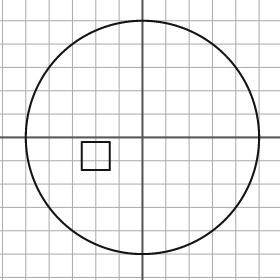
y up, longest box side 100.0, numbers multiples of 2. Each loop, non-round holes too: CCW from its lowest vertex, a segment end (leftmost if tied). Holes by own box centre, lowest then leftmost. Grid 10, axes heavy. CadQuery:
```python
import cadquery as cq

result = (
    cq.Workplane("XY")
    .moveTo(0.0, 0.0)
    .circle(50.0)
    .moveTo(-26.0, -14.0)
    .lineTo(-14.0, -14.0)
    .lineTo(-14.0, -2.0)
    .lineTo(-26.0, -2.0)
    .close()
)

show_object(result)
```